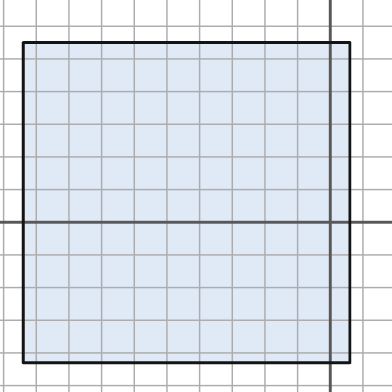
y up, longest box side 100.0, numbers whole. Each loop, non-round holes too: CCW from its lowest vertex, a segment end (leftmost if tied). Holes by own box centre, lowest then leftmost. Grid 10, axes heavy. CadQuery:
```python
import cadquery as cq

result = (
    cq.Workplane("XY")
    .moveTo(-94.0, -43.0)
    .lineTo(6.0, -43.0)
    .lineTo(6.0, 55.0)
    .lineTo(-94.0, 55.0)
    .close()
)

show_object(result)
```